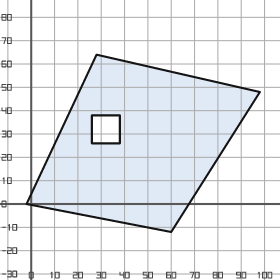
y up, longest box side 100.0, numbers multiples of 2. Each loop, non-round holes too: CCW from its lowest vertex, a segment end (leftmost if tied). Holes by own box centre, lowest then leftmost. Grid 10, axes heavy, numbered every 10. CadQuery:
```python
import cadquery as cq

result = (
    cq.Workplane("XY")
    .moveTo(60.0, -12.0)
    .lineTo(98.0, 48.0)
    .lineTo(28.0, 64.0)
    .lineTo(-2.0, 0.0)
    .close()
    .moveTo(26.0, 26.0)
    .lineTo(38.0, 26.0)
    .lineTo(38.0, 38.0)
    .lineTo(26.0, 38.0)
    .close()
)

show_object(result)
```